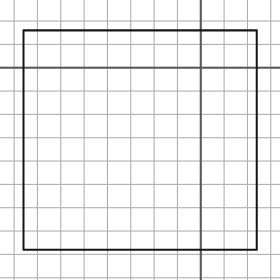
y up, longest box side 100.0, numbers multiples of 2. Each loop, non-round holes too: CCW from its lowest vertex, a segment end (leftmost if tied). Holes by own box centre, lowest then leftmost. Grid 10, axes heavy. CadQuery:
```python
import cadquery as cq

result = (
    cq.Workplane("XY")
    .moveTo(-76.0, -78.0)
    .lineTo(24.0, -78.0)
    .lineTo(24.0, 16.0)
    .lineTo(-76.0, 16.0)
    .close()
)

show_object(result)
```